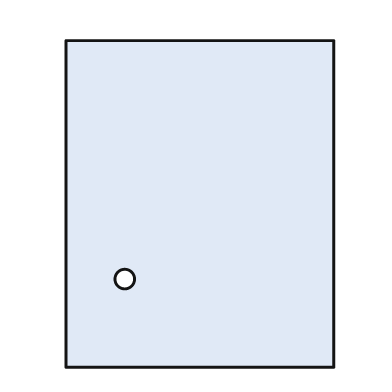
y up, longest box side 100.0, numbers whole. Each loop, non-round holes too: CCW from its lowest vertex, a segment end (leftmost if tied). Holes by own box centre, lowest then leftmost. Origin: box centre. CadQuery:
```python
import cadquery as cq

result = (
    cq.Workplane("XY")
    .moveTo(-41.0, -50.0)
    .lineTo(41.0, -50.0)
    .lineTo(41.0, 50.0)
    .lineTo(-41.0, 50.0)
    .close()
    .moveTo(-23.0, -23.0)
    .circle(3.0)
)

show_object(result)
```